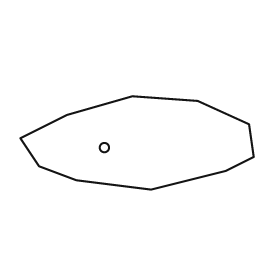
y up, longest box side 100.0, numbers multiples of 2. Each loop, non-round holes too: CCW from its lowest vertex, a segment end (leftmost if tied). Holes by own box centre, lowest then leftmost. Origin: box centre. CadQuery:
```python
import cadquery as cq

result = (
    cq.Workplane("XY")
    .moveTo(6.0, -20.0)
    .lineTo(38.0, -12.0)
    .lineTo(50.0, -6.0)
    .lineTo(48.0, 8.0)
    .lineTo(26.0, 18.0)
    .lineTo(-2.0, 20.0)
    .lineTo(-30.0, 12.0)
    .lineTo(-50.0, 2.0)
    .lineTo(-42.0, -10.0)
    .lineTo(-26.0, -16.0)
    .close()
    .moveTo(-14.0, -2.0)
    .circle(2.0)
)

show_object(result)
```